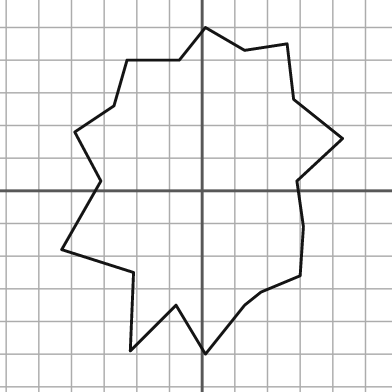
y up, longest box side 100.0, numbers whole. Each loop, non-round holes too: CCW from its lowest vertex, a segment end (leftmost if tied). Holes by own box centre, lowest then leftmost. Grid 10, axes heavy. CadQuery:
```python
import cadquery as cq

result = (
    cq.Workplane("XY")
    .moveTo(1.0, -50.0)
    .lineTo(13.0, -35.0)
    .lineTo(18.0, -31.0)
    .lineTo(30.0, -26.0)
    .lineTo(31.0, -11.0)
    .lineTo(29.0, 3.0)
    .lineTo(43.0, 16.0)
    .lineTo(28.0, 28.0)
    .lineTo(26.0, 45.0)
    .lineTo(13.0, 43.0)
    .lineTo(1.0, 50.0)
    .lineTo(-7.0, 40.0)
    .lineTo(-23.0, 40.0)
    .lineTo(-27.0, 26.0)
    .lineTo(-39.0, 18.0)
    .lineTo(-31.0, 3.0)
    .lineTo(-43.0, -18.0)
    .lineTo(-21.0, -25.0)
    .lineTo(-22.0, -49.0)
    .lineTo(-8.0, -35.0)
    .close()
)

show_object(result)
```